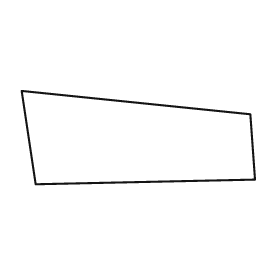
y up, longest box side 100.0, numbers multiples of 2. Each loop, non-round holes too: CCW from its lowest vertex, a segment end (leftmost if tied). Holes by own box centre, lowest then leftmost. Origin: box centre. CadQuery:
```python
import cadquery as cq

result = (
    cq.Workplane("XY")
    .moveTo(-44.0, -20.0)
    .lineTo(50.0, -18.0)
    .lineTo(48.0, 10.0)
    .lineTo(-50.0, 20.0)
    .close()
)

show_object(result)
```